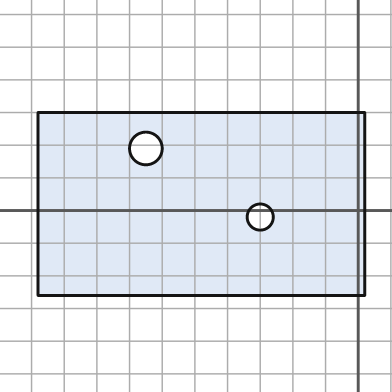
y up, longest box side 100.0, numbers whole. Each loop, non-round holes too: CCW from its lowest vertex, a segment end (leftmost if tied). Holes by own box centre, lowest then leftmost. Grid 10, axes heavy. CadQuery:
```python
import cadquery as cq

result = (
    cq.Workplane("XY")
    .moveTo(-98.0, -26.0)
    .lineTo(2.0, -26.0)
    .lineTo(2.0, 30.0)
    .lineTo(-98.0, 30.0)
    .close()
    .moveTo(-30.0, -2.0)
    .circle(4.0)
    .moveTo(-65.0, 19.0)
    .circle(5.0)
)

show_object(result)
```